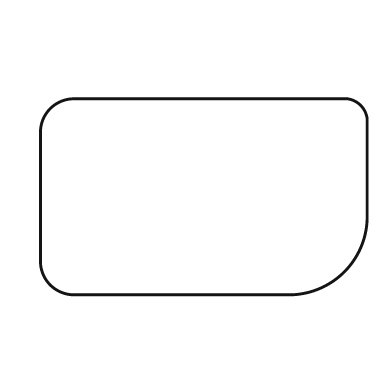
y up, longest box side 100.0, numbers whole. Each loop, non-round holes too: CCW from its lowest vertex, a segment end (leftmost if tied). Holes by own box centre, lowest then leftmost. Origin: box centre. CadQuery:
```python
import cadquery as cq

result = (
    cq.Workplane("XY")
    .moveTo(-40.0, -30.0)
    .lineTo(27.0, -30.0)
    .threePointArc((43.0, -23.0), (50.0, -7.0))
    .lineTo(50.0, 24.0)
    .threePointArc((48.0, 28.0), (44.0, 30.0))
    .lineTo(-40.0, 30.0)
    .threePointArc((-47.0, 27.0), (-50.0, 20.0))
    .lineTo(-50.0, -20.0)
    .threePointArc((-47.0, -27.0), (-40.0, -30.0))
    .close()
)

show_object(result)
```